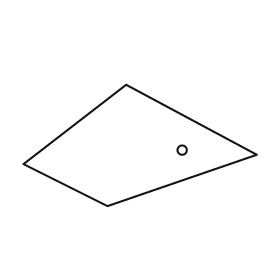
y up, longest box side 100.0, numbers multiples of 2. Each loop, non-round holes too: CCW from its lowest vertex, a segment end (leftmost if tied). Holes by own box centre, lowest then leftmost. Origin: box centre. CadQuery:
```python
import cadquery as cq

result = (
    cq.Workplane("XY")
    .moveTo(-14.0, -26.0)
    .lineTo(50.0, -4.0)
    .lineTo(-6.0, 26.0)
    .lineTo(-50.0, -8.0)
    .close()
    .moveTo(18.0, -2.0)
    .circle(2.0)
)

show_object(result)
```